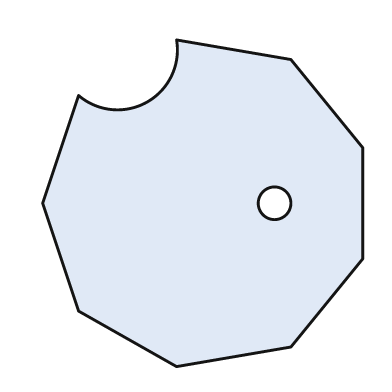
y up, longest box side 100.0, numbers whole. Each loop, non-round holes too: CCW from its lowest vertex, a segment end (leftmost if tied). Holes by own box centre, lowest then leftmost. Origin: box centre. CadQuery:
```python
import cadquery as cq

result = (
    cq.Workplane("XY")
    .moveTo(-8.0, -50.0)
    .lineTo(27.0, -44.0)
    .lineTo(49.0, -17.0)
    .lineTo(49.0, 17.0)
    .lineTo(27.0, 44.0)
    .lineTo(-8.0, 50.0)
    .threePointArc((-17.0, 31.0), (-38.0, 33.0))
    .lineTo(-49.0, 0.0)
    .lineTo(-38.0, -33.0)
    .close()
    .moveTo(22.0, 0.0)
    .circle(5.0)
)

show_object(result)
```